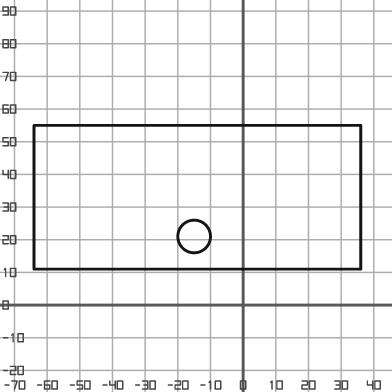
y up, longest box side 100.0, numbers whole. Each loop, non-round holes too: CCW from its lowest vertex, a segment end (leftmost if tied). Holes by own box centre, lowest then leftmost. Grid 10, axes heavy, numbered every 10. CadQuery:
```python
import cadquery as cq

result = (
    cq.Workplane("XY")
    .moveTo(-64.0, 11.0)
    .lineTo(36.0, 11.0)
    .lineTo(36.0, 55.0)
    .lineTo(-64.0, 55.0)
    .close()
    .moveTo(-15.0, 21.0)
    .circle(5.0)
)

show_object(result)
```